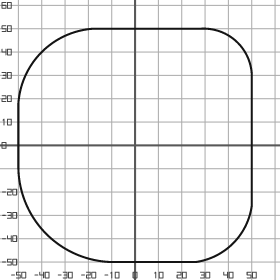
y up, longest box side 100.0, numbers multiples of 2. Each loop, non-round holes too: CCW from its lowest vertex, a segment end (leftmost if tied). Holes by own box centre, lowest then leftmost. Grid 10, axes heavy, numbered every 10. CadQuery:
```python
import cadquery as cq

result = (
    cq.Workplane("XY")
    .moveTo(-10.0, -50.0)
    .lineTo(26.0, -50.0)
    .threePointArc((42.0, -42.0), (50.0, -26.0))
    .lineTo(50.0, 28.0)
    .threePointArc((44.0, 44.0), (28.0, 50.0))
    .lineTo(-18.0, 50.0)
    .threePointArc((-40.0, 40.0), (-50.0, 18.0))
    .lineTo(-50.0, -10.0)
    .threePointArc((-38.0, -38.0), (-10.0, -50.0))
    .close()
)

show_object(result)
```